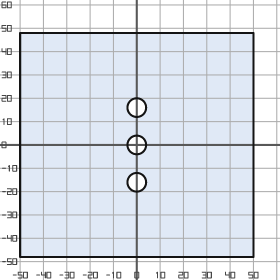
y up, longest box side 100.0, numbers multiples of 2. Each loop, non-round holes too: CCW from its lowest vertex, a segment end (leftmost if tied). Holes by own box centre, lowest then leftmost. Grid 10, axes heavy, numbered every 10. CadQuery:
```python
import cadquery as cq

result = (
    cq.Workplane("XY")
    .moveTo(-50.0, -48.0)
    .lineTo(50.0, -48.0)
    .lineTo(50.0, 48.0)
    .lineTo(-50.0, 48.0)
    .close()
    .moveTo(0.0, -16.0)
    .circle(4.0)
    .moveTo(0.0, 0.0)
    .circle(4.0)
    .moveTo(0.0, 16.0)
    .circle(4.0)
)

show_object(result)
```